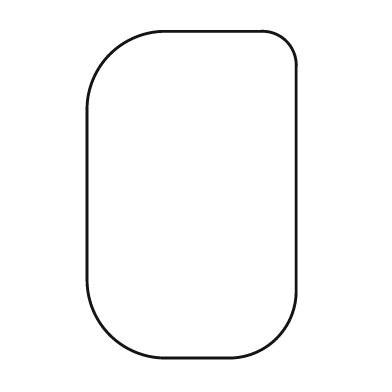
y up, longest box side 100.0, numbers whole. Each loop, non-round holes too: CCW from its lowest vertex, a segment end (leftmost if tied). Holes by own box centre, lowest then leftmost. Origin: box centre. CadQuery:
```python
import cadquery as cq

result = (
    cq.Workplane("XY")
    .moveTo(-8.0, -50.0)
    .lineTo(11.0, -50.0)
    .threePointArc((26.0, -44.0), (32.0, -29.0))
    .lineTo(32.0, 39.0)
    .threePointArc((29.0, 47.0), (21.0, 50.0))
    .lineTo(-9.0, 50.0)
    .threePointArc((-25.0, 43.0), (-32.0, 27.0))
    .lineTo(-32.0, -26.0)
    .threePointArc((-25.0, -43.0), (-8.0, -50.0))
    .close()
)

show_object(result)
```